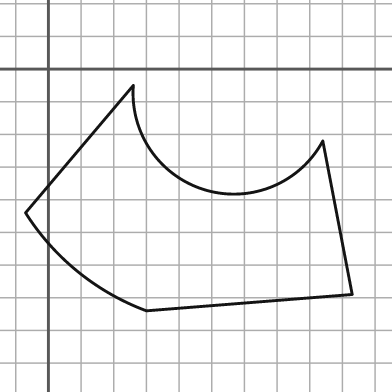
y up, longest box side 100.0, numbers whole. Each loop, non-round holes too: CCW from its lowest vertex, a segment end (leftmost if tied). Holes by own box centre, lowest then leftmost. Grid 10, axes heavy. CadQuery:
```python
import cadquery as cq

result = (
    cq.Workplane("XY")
    .moveTo(30.0, -74.0)
    .lineTo(93.0, -69.0)
    .lineTo(84.0, -22.0)
    .threePointArc((48.0, -37.0), (26.0, -5.0))
    .lineTo(-7.0, -44.0)
    .threePointArc((9.0, -62.0), (30.0, -74.0))
    .close()
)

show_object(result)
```